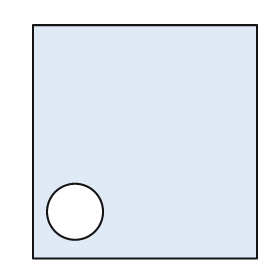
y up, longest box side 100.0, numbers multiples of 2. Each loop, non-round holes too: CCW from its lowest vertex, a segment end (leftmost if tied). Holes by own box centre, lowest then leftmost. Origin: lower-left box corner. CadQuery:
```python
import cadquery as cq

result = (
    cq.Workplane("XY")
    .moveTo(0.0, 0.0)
    .lineTo(96.0, 0.0)
    .lineTo(96.0, 100.0)
    .lineTo(0.0, 100.0)
    .close()
    .moveTo(18.0, 20.0)
    .circle(12.0)
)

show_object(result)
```